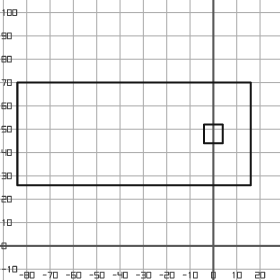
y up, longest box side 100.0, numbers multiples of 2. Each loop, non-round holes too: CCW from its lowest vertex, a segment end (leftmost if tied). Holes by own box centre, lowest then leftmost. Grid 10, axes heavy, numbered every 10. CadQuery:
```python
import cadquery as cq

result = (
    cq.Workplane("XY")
    .moveTo(-84.0, 26.0)
    .lineTo(16.0, 26.0)
    .lineTo(16.0, 70.0)
    .lineTo(-84.0, 70.0)
    .close()
    .moveTo(-4.0, 44.0)
    .lineTo(4.0, 44.0)
    .lineTo(4.0, 52.0)
    .lineTo(-4.0, 52.0)
    .close()
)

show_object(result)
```